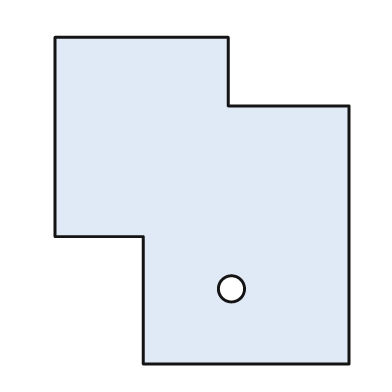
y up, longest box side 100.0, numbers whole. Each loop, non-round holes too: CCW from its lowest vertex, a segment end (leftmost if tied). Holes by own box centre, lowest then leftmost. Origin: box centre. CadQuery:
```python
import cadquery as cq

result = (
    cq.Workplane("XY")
    .moveTo(-18.0, -50.0)
    .lineTo(45.0, -50.0)
    .lineTo(45.0, 29.0)
    .lineTo(8.0, 29.0)
    .lineTo(8.0, 50.0)
    .lineTo(-45.0, 50.0)
    .lineTo(-45.0, -11.0)
    .lineTo(-18.0, -11.0)
    .close()
    .moveTo(9.0, -27.0)
    .circle(4.0)
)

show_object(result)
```